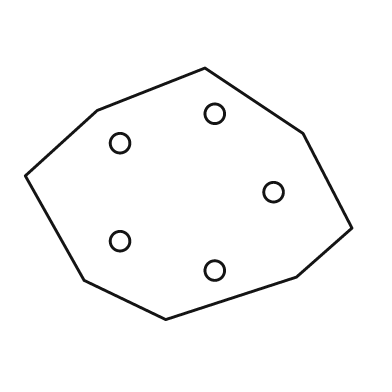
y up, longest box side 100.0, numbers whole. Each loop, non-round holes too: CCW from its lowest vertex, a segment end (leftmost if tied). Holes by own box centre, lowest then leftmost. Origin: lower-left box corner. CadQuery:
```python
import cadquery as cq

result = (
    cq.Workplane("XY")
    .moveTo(43.0, 0.0)
    .lineTo(83.0, 13.0)
    .lineTo(100.0, 28.0)
    .lineTo(85.0, 57.0)
    .lineTo(55.0, 77.0)
    .lineTo(22.0, 64.0)
    .lineTo(0.0, 44.0)
    .lineTo(18.0, 12.0)
    .close()
    .moveTo(58.0, 15.0)
    .circle(3.0)
    .moveTo(29.0, 24.0)
    .circle(3.0)
    .moveTo(76.0, 39.0)
    .circle(3.0)
    .moveTo(29.0, 54.0)
    .circle(3.0)
    .moveTo(58.0, 63.0)
    .circle(3.0)
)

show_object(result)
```